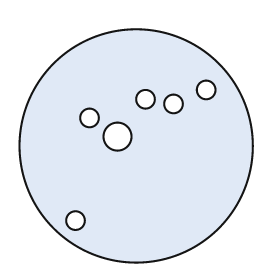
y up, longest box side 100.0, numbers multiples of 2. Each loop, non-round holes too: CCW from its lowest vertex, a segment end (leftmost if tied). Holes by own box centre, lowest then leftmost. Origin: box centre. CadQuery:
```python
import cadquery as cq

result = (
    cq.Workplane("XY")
    .moveTo(0.0, 0.0)
    .circle(50.0)
    .moveTo(-26.0, -32.0)
    .circle(4.0)
    .moveTo(-8.0, 4.0)
    .circle(6.0)
    .moveTo(-20.0, 12.0)
    .circle(4.0)
    .moveTo(16.0, 18.0)
    .circle(4.0)
    .moveTo(4.0, 20.0)
    .circle(4.0)
    .moveTo(30.0, 24.0)
    .circle(4.0)
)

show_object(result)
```